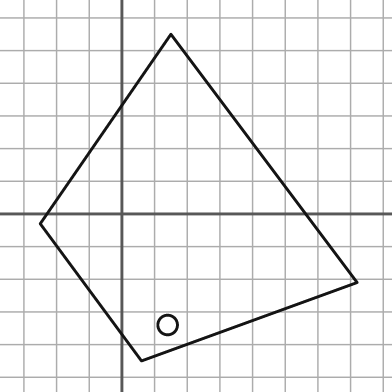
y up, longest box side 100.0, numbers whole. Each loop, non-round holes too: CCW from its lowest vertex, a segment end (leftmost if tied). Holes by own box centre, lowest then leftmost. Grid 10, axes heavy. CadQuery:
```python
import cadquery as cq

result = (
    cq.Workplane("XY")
    .moveTo(6.0, -45.0)
    .lineTo(72.0, -21.0)
    .lineTo(15.0, 55.0)
    .lineTo(-25.0, -3.0)
    .close()
    .moveTo(14.0, -34.0)
    .circle(3.0)
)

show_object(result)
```